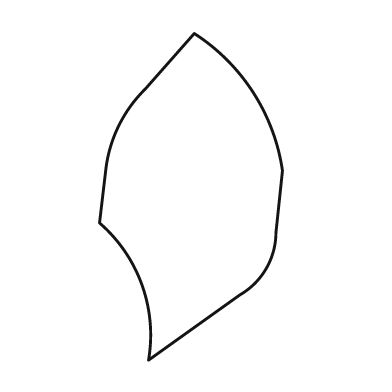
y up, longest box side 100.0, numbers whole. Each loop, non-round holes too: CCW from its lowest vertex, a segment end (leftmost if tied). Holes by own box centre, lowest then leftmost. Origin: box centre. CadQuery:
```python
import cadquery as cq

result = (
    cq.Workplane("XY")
    .moveTo(-13.0, -50.0)
    .lineTo(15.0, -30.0)
    .threePointArc((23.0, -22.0), (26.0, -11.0))
    .lineTo(28.0, 8.0)
    .threePointArc((19.0, 32.0), (1.0, 50.0))
    .lineTo(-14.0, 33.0)
    .threePointArc((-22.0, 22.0), (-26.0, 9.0))
    .lineTo(-28.0, -8.0)
    .threePointArc((-15.0, -27.0), (-13.0, -50.0))
    .close()
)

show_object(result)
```